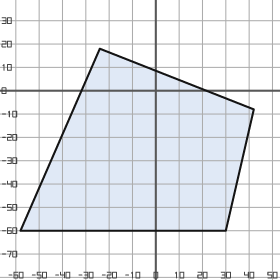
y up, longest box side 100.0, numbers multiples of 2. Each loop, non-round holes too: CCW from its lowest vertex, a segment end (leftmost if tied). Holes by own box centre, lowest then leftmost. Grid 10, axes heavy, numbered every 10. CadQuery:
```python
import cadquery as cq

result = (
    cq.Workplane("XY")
    .moveTo(-58.0, -60.0)
    .lineTo(30.0, -60.0)
    .lineTo(42.0, -8.0)
    .lineTo(-24.0, 18.0)
    .close()
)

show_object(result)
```